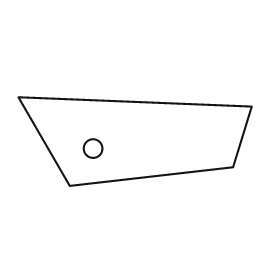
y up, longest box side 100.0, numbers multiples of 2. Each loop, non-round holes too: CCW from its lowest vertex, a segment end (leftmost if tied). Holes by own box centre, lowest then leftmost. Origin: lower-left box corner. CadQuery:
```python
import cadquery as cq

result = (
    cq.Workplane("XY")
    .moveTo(22.0, 0.0)
    .lineTo(92.0, 8.0)
    .lineTo(100.0, 34.0)
    .lineTo(0.0, 38.0)
    .close()
    .moveTo(32.0, 16.0)
    .circle(4.0)
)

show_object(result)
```